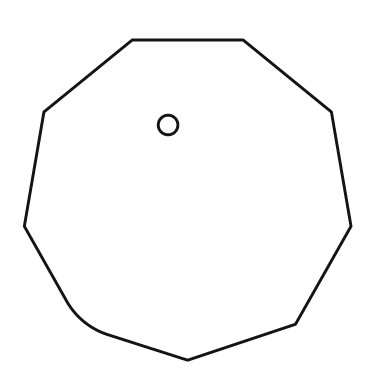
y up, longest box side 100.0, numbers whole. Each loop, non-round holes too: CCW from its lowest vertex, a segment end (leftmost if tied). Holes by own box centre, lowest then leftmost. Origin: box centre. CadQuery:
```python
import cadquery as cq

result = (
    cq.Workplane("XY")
    .moveTo(0.0, -49.0)
    .lineTo(33.0, -38.0)
    .lineTo(50.0, -8.0)
    .lineTo(44.0, 27.0)
    .lineTo(17.0, 49.0)
    .lineTo(-17.0, 49.0)
    .lineTo(-44.0, 27.0)
    .lineTo(-50.0, -8.0)
    .lineTo(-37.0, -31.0)
    .threePointArc((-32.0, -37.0), (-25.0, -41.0))
    .close()
    .moveTo(-6.0, 23.0)
    .circle(3.0)
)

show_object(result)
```